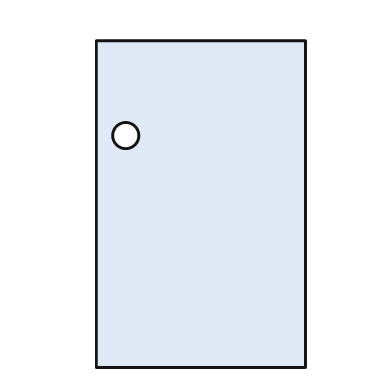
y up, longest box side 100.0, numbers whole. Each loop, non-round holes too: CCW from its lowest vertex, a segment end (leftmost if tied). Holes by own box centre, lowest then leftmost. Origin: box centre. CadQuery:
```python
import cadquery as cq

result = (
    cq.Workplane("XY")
    .moveTo(-32.0, -50.0)
    .lineTo(32.0, -50.0)
    .lineTo(32.0, 50.0)
    .lineTo(-32.0, 50.0)
    .close()
    .moveTo(-23.0, 21.0)
    .circle(4.0)
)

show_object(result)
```